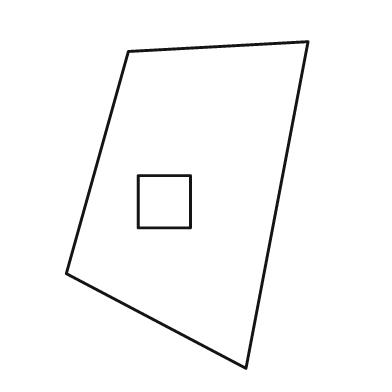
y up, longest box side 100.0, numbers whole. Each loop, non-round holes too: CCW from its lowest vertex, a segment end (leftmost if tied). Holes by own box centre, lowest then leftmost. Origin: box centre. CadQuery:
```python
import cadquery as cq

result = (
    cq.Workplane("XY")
    .moveTo(18.0, -50.0)
    .lineTo(37.0, 50.0)
    .lineTo(-18.0, 47.0)
    .lineTo(-37.0, -21.0)
    .close()
    .moveTo(-15.0, -7.0)
    .lineTo(1.0, -7.0)
    .lineTo(1.0, 9.0)
    .lineTo(-15.0, 9.0)
    .close()
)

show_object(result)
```